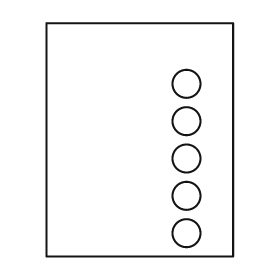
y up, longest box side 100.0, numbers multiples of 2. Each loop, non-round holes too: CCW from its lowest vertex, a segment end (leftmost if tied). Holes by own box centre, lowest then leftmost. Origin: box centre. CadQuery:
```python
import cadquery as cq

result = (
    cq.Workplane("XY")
    .moveTo(-40.0, -50.0)
    .lineTo(40.0, -50.0)
    .lineTo(40.0, 50.0)
    .lineTo(-40.0, 50.0)
    .close()
    .moveTo(20.0, -40.0)
    .circle(6.0)
    .moveTo(20.0, -24.0)
    .circle(6.0)
    .moveTo(20.0, -8.0)
    .circle(6.0)
    .moveTo(20.0, 8.0)
    .circle(6.0)
    .moveTo(20.0, 24.0)
    .circle(6.0)
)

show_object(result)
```